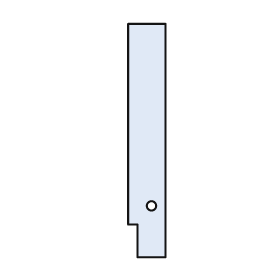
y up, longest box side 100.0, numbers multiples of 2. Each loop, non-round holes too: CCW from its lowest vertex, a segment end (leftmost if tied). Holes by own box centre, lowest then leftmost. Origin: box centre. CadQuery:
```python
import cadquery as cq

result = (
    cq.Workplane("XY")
    .moveTo(-4.0, -50.0)
    .lineTo(8.0, -50.0)
    .lineTo(8.0, 50.0)
    .lineTo(-8.0, 50.0)
    .lineTo(-8.0, -36.0)
    .lineTo(-4.0, -36.0)
    .close()
    .moveTo(2.0, -28.0)
    .circle(2.0)
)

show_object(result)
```